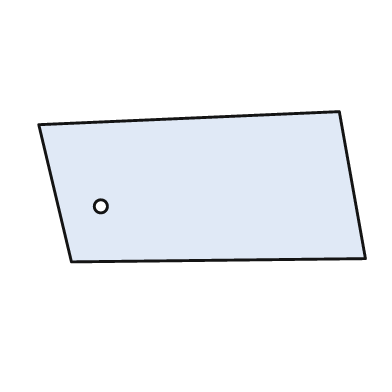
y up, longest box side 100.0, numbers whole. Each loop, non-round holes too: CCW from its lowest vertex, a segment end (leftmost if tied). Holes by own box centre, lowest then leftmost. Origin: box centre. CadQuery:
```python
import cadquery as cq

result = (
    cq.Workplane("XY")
    .moveTo(-40.0, -23.0)
    .lineTo(50.0, -22.0)
    .lineTo(42.0, 23.0)
    .lineTo(-50.0, 19.0)
    .close()
    .moveTo(-31.0, -6.0)
    .circle(2.0)
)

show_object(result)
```